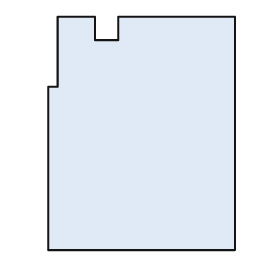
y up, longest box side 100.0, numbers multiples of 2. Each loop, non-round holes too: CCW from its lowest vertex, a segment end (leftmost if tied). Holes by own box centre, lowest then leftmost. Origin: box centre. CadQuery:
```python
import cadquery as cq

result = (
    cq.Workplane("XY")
    .moveTo(-40.0, -50.0)
    .lineTo(40.0, -50.0)
    .lineTo(40.0, 50.0)
    .lineTo(-10.0, 50.0)
    .lineTo(-10.0, 40.0)
    .lineTo(-20.0, 40.0)
    .lineTo(-20.0, 50.0)
    .lineTo(-36.0, 50.0)
    .lineTo(-36.0, 20.0)
    .lineTo(-40.0, 20.0)
    .close()
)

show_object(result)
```